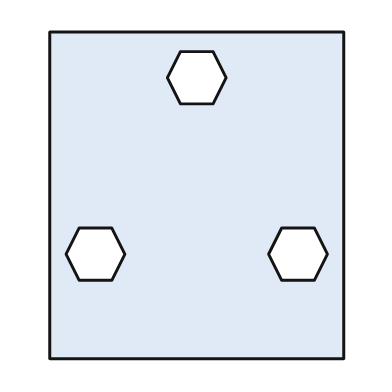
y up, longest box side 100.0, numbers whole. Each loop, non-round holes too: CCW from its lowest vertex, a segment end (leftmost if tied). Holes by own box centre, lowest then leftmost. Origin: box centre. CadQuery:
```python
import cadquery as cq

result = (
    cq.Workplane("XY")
    .moveTo(-45.0, -50.0)
    .lineTo(45.0, -50.0)
    .lineTo(45.0, 50.0)
    .lineTo(-45.0, 50.0)
    .close()
    .moveTo(-36.0, -26.0)
    .lineTo(-26.0, -26.0)
    .lineTo(-22.0, -18.0)
    .lineTo(-26.0, -10.0)
    .lineTo(-36.0, -10.0)
    .lineTo(-40.0, -18.0)
    .close()
    .moveTo(26.0, -26.0)
    .lineTo(36.0, -26.0)
    .lineTo(40.0, -18.0)
    .lineTo(36.0, -10.0)
    .lineTo(26.0, -10.0)
    .lineTo(22.0, -18.0)
    .close()
    .moveTo(-5.0, 28.0)
    .lineTo(5.0, 28.0)
    .lineTo(9.0, 36.0)
    .lineTo(5.0, 44.0)
    .lineTo(-5.0, 44.0)
    .lineTo(-9.0, 36.0)
    .close()
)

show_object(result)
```